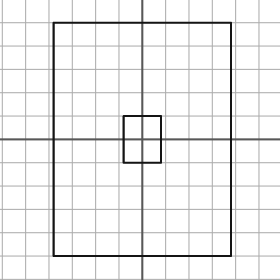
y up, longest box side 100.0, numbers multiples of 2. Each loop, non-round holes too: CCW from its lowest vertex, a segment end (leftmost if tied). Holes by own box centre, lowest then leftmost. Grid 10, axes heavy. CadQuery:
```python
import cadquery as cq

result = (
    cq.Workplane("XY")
    .moveTo(-38.0, -50.0)
    .lineTo(38.0, -50.0)
    .lineTo(38.0, 50.0)
    .lineTo(-38.0, 50.0)
    .close()
    .moveTo(-8.0, -10.0)
    .lineTo(8.0, -10.0)
    .lineTo(8.0, 10.0)
    .lineTo(-8.0, 10.0)
    .close()
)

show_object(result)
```